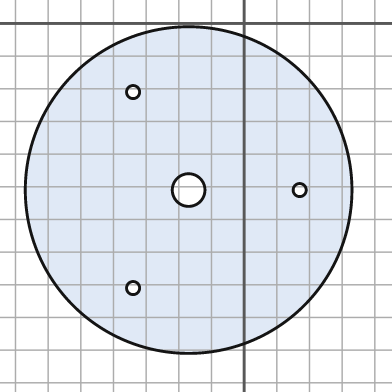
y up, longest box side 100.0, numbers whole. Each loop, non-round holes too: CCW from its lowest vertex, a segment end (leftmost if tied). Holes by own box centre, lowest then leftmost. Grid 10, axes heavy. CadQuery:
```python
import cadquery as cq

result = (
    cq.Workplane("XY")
    .moveTo(-17.0, -51.0)
    .circle(50.0)
    .moveTo(-34.0, -81.0)
    .circle(2.0)
    .moveTo(-17.0, -51.0)
    .circle(5.0)
    .moveTo(17.0, -51.0)
    .circle(2.0)
    .moveTo(-34.0, -21.0)
    .circle(2.0)
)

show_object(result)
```